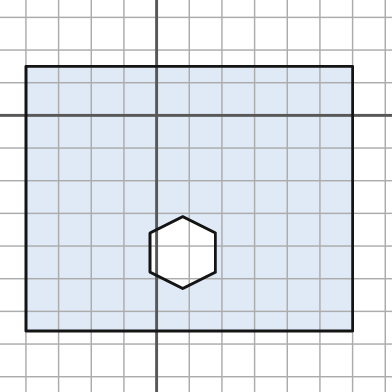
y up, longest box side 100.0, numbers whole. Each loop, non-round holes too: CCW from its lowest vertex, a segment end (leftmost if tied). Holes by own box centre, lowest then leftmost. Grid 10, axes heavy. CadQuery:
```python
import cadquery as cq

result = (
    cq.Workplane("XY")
    .moveTo(-40.0, -66.0)
    .lineTo(60.0, -66.0)
    .lineTo(60.0, 15.0)
    .lineTo(-40.0, 15.0)
    .close()
    .moveTo(8.0, -53.0)
    .lineTo(18.0, -48.0)
    .lineTo(18.0, -36.0)
    .lineTo(8.0, -31.0)
    .lineTo(-2.0, -36.0)
    .lineTo(-2.0, -48.0)
    .close()
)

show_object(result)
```